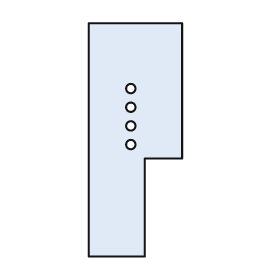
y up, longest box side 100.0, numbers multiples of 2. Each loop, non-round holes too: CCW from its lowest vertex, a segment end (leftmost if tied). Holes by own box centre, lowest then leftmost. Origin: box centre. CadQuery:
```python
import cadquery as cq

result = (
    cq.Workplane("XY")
    .moveTo(-20.0, -50.0)
    .lineTo(4.0, -50.0)
    .lineTo(4.0, -8.0)
    .lineTo(20.0, -8.0)
    .lineTo(20.0, 50.0)
    .lineTo(-20.0, 50.0)
    .close()
    .moveTo(-2.0, -2.0)
    .circle(2.0)
    .moveTo(-2.0, 6.0)
    .circle(2.0)
    .moveTo(-2.0, 14.0)
    .circle(2.0)
    .moveTo(-2.0, 22.0)
    .circle(2.0)
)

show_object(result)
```